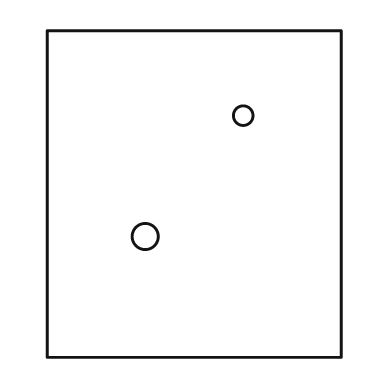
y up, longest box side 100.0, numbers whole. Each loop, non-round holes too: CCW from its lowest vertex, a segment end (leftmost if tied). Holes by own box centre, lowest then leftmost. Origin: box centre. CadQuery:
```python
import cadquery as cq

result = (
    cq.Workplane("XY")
    .moveTo(-45.0, -50.0)
    .lineTo(45.0, -50.0)
    .lineTo(45.0, 50.0)
    .lineTo(-45.0, 50.0)
    .close()
    .moveTo(-15.0, -13.0)
    .circle(4.0)
    .moveTo(15.0, 24.0)
    .circle(3.0)
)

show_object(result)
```